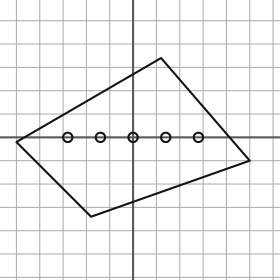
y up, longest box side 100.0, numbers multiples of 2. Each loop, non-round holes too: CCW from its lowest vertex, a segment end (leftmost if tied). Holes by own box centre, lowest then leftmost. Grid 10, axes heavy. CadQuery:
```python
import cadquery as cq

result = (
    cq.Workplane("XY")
    .moveTo(-18.0, -34.0)
    .lineTo(50.0, -10.0)
    .lineTo(12.0, 34.0)
    .lineTo(-50.0, -2.0)
    .close()
    .moveTo(-28.0, 0.0)
    .circle(2.0)
    .moveTo(-14.0, 0.0)
    .circle(2.0)
    .moveTo(0.0, 0.0)
    .circle(2.0)
    .moveTo(14.0, 0.0)
    .circle(2.0)
    .moveTo(28.0, 0.0)
    .circle(2.0)
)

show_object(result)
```